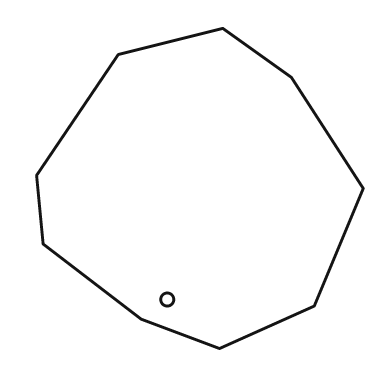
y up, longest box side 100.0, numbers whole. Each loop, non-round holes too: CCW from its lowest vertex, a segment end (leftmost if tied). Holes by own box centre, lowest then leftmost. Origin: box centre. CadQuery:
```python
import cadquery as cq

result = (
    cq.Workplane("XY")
    .moveTo(6.0, -49.0)
    .lineTo(35.0, -36.0)
    .lineTo(50.0, 0.0)
    .lineTo(28.0, 34.0)
    .lineTo(7.0, 49.0)
    .lineTo(-25.0, 41.0)
    .lineTo(-50.0, 4.0)
    .lineTo(-48.0, -17.0)
    .lineTo(-18.0, -40.0)
    .close()
    .moveTo(-10.0, -34.0)
    .circle(2.0)
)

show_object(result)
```